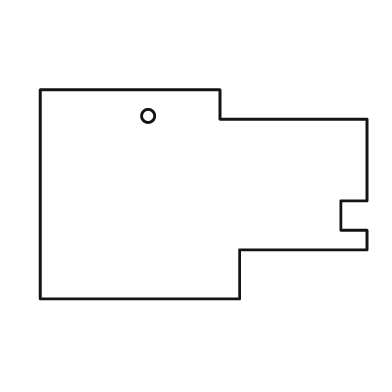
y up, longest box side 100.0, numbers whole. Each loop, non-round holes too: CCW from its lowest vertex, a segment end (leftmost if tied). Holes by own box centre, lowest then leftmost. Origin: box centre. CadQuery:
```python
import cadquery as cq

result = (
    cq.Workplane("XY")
    .moveTo(-50.0, -32.0)
    .lineTo(11.0, -32.0)
    .lineTo(11.0, -17.0)
    .lineTo(50.0, -17.0)
    .lineTo(50.0, -11.0)
    .lineTo(42.0, -11.0)
    .lineTo(42.0, -2.0)
    .lineTo(50.0, -2.0)
    .lineTo(50.0, 23.0)
    .lineTo(5.0, 23.0)
    .lineTo(5.0, 32.0)
    .lineTo(-50.0, 32.0)
    .close()
    .moveTo(-17.0, 24.0)
    .circle(2.0)
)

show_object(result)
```